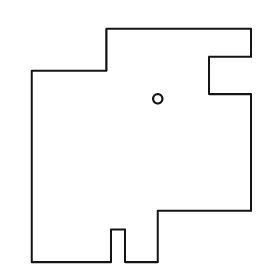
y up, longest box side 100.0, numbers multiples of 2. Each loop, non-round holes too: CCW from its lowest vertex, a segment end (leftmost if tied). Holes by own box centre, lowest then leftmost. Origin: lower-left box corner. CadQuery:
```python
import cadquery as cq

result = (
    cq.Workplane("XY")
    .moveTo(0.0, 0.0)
    .lineTo(34.0, 0.0)
    .lineTo(34.0, 14.0)
    .lineTo(40.0, 14.0)
    .lineTo(40.0, 0.0)
    .lineTo(54.0, 0.0)
    .lineTo(54.0, 22.0)
    .lineTo(94.0, 22.0)
    .lineTo(94.0, 72.0)
    .lineTo(76.0, 72.0)
    .lineTo(76.0, 88.0)
    .lineTo(94.0, 88.0)
    .lineTo(94.0, 100.0)
    .lineTo(32.0, 100.0)
    .lineTo(32.0, 82.0)
    .lineTo(0.0, 82.0)
    .close()
    .moveTo(54.0, 70.0)
    .circle(2.0)
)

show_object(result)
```